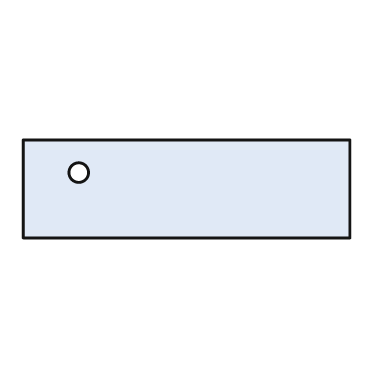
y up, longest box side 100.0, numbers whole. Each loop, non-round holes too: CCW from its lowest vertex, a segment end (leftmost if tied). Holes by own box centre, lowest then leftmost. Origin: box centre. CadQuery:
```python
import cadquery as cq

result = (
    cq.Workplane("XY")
    .moveTo(-50.0, -15.0)
    .lineTo(50.0, -15.0)
    .lineTo(50.0, 15.0)
    .lineTo(-50.0, 15.0)
    .close()
    .moveTo(-33.0, 5.0)
    .circle(3.0)
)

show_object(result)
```